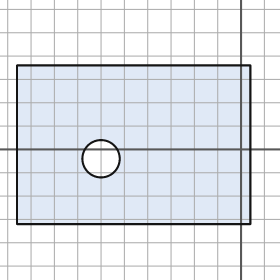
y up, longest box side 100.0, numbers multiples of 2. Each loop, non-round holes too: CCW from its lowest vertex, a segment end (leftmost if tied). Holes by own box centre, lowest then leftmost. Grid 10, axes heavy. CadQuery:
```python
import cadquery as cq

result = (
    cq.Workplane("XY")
    .moveTo(-96.0, -32.0)
    .lineTo(4.0, -32.0)
    .lineTo(4.0, 36.0)
    .lineTo(-96.0, 36.0)
    .close()
    .moveTo(-60.0, -4.0)
    .circle(8.0)
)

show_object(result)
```